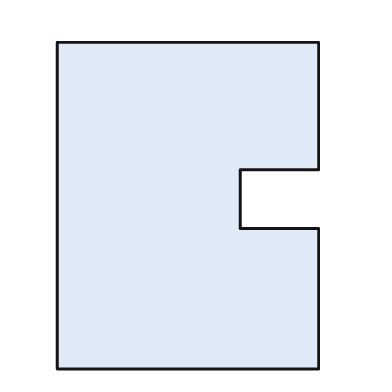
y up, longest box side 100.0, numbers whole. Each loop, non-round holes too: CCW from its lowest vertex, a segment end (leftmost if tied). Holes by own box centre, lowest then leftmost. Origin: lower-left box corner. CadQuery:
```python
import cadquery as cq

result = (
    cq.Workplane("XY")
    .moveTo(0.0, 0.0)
    .lineTo(80.0, 0.0)
    .lineTo(80.0, 43.0)
    .lineTo(56.0, 43.0)
    .lineTo(56.0, 61.0)
    .lineTo(80.0, 61.0)
    .lineTo(80.0, 100.0)
    .lineTo(0.0, 100.0)
    .close()
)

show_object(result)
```